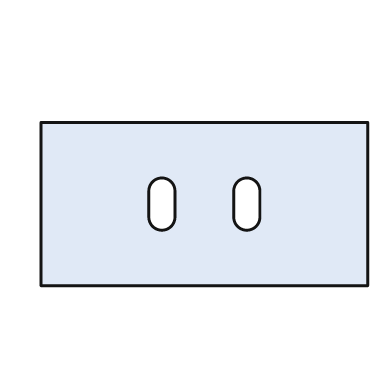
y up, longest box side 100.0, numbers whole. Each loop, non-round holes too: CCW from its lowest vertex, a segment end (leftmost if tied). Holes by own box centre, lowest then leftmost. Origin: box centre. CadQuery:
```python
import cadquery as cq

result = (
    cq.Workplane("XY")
    .moveTo(-50.0, -25.0)
    .lineTo(50.0, -25.0)
    .lineTo(50.0, 25.0)
    .lineTo(-50.0, 25.0)
    .close()
    .moveTo(-17.0, -4.0)
    .threePointArc((-13.0, -8.0), (-9.0, -4.0))
    .lineTo(-9.0, 4.0)
    .threePointArc((-13.0, 8.0), (-17.0, 4.0))
    .close()
    .moveTo(9.0, -4.0)
    .threePointArc((13.0, -8.0), (17.0, -4.0))
    .lineTo(17.0, 4.0)
    .threePointArc((13.0, 8.0), (9.0, 4.0))
    .close()
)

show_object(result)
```